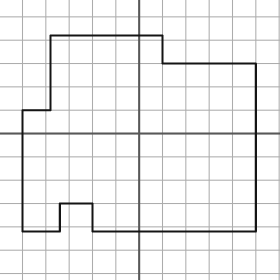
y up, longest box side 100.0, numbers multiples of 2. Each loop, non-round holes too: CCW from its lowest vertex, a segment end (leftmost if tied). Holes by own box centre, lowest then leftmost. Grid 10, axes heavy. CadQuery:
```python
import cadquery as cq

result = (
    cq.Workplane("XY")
    .moveTo(-50.0, -42.0)
    .lineTo(-34.0, -42.0)
    .lineTo(-34.0, -30.0)
    .lineTo(-20.0, -30.0)
    .lineTo(-20.0, -42.0)
    .lineTo(50.0, -42.0)
    .lineTo(50.0, 30.0)
    .lineTo(10.0, 30.0)
    .lineTo(10.0, 42.0)
    .lineTo(-38.0, 42.0)
    .lineTo(-38.0, 10.0)
    .lineTo(-50.0, 10.0)
    .close()
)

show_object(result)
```